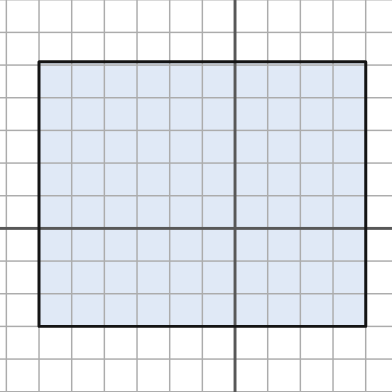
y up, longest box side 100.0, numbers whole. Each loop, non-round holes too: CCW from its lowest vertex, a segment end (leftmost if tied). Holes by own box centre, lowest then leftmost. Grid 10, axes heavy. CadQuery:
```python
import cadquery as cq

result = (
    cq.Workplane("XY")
    .moveTo(-60.0, -30.0)
    .lineTo(40.0, -30.0)
    .lineTo(40.0, 51.0)
    .lineTo(-60.0, 51.0)
    .close()
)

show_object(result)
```